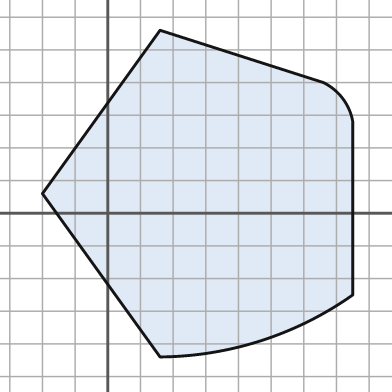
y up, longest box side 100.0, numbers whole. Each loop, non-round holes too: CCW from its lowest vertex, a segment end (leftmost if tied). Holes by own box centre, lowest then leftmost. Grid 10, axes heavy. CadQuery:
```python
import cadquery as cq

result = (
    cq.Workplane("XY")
    .moveTo(16.0, -44.0)
    .threePointArc((47.0, -39.0), (75.0, -25.0))
    .lineTo(75.0, 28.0)
    .threePointArc((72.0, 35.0), (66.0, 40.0))
    .lineTo(16.0, 56.0)
    .lineTo(-20.0, 6.0)
    .close()
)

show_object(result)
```